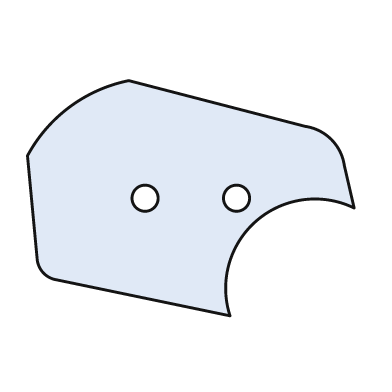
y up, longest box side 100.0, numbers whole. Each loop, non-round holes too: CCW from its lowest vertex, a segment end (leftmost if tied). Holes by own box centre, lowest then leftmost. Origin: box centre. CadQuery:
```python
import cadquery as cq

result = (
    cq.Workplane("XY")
    .moveTo(12.0, -36.0)
    .threePointArc((20.0, -7.0), (50.0, -3.0))
    .lineTo(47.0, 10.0)
    .threePointArc((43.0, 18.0), (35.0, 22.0))
    .lineTo(-19.0, 36.0)
    .threePointArc((-37.0, 28.0), (-50.0, 13.0))
    .lineTo(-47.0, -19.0)
    .threePointArc((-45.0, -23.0), (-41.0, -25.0))
    .close()
    .moveTo(-14.0, 0.0)
    .circle(4.0)
    .moveTo(14.0, 0.0)
    .circle(4.0)
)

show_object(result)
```